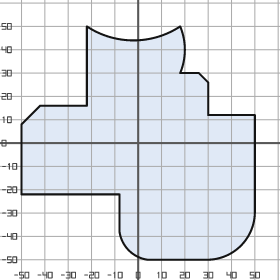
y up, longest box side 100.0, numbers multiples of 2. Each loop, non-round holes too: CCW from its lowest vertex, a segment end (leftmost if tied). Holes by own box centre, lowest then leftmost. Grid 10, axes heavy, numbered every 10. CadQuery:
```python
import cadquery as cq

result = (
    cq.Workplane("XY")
    .moveTo(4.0, -50.0)
    .lineTo(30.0, -50.0)
    .threePointArc((44.0, -44.0), (50.0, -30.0))
    .lineTo(50.0, 12.0)
    .lineTo(30.0, 12.0)
    .lineTo(30.0, 26.0)
    .lineTo(26.0, 30.0)
    .lineTo(18.0, 30.0)
    .threePointArc((20.0, 40.0), (18.0, 50.0))
    .threePointArc((-2.0, 44.0), (-22.0, 50.0))
    .lineTo(-22.0, 16.0)
    .lineTo(-42.0, 16.0)
    .lineTo(-50.0, 8.0)
    .lineTo(-50.0, -22.0)
    .lineTo(-8.0, -22.0)
    .lineTo(-8.0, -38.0)
    .threePointArc((-4.0, -46.0), (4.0, -50.0))
    .close()
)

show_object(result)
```